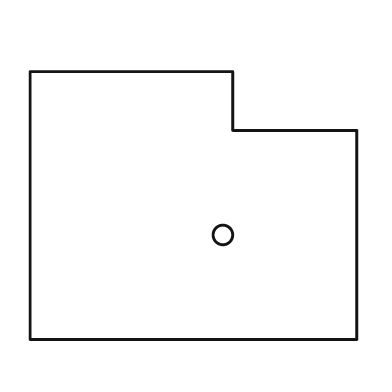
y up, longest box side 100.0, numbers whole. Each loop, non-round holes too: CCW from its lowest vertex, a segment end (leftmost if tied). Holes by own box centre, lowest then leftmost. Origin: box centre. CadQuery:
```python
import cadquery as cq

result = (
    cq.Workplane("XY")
    .moveTo(-50.0, -41.0)
    .lineTo(50.0, -41.0)
    .lineTo(50.0, 23.0)
    .lineTo(12.0, 23.0)
    .lineTo(12.0, 41.0)
    .lineTo(-50.0, 41.0)
    .close()
    .moveTo(9.0, -9.0)
    .circle(3.0)
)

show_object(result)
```